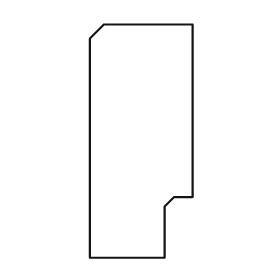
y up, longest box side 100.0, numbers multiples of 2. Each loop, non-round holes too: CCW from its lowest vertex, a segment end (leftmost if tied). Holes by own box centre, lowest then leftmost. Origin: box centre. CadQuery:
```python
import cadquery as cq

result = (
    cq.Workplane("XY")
    .moveTo(-22.0, -50.0)
    .lineTo(10.0, -50.0)
    .lineTo(10.0, -28.0)
    .lineTo(14.0, -24.0)
    .lineTo(22.0, -24.0)
    .lineTo(22.0, 50.0)
    .lineTo(-16.0, 50.0)
    .lineTo(-22.0, 44.0)
    .close()
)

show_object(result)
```